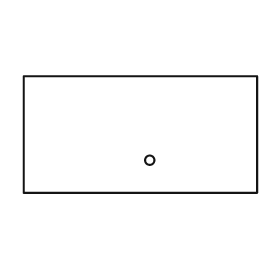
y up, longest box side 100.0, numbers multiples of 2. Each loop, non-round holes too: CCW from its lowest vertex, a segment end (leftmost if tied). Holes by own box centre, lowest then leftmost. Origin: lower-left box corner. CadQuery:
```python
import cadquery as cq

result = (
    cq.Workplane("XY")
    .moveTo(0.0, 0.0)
    .lineTo(100.0, 0.0)
    .lineTo(100.0, 50.0)
    .lineTo(0.0, 50.0)
    .close()
    .moveTo(54.0, 14.0)
    .circle(2.0)
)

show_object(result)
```